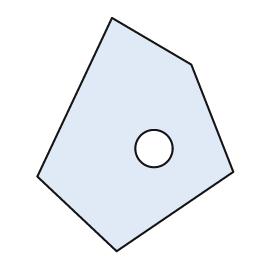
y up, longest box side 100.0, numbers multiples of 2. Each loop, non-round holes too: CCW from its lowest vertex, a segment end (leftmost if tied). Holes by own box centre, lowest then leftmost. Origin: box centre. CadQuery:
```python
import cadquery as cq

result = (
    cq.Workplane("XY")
    .moveTo(-8.0, -50.0)
    .lineTo(42.0, -16.0)
    .lineTo(24.0, 30.0)
    .lineTo(-10.0, 50.0)
    .lineTo(-42.0, -18.0)
    .close()
    .moveTo(8.0, -6.0)
    .circle(8.0)
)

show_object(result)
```